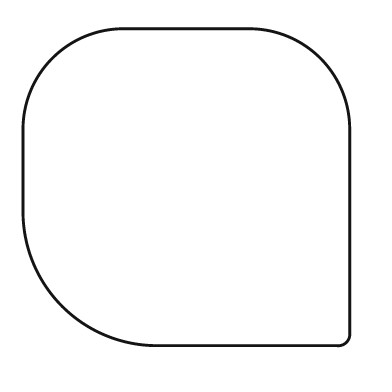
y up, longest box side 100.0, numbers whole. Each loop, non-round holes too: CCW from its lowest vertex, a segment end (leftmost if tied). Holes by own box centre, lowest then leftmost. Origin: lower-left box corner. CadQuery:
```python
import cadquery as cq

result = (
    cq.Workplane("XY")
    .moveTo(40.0, 0.0)
    .lineTo(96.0, 0.0)
    .threePointArc((99.0, 1.0), (100.0, 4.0))
    .lineTo(100.0, 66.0)
    .threePointArc((91.0, 88.0), (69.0, 97.0))
    .lineTo(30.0, 97.0)
    .threePointArc((9.0, 88.0), (0.0, 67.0))
    .lineTo(0.0, 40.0)
    .threePointArc((12.0, 12.0), (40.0, 0.0))
    .close()
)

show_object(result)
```